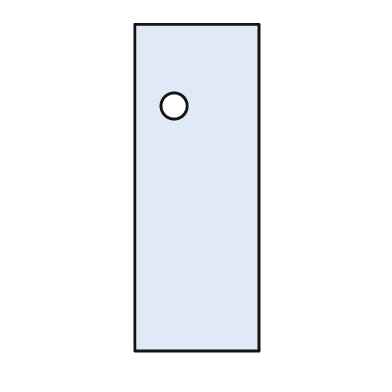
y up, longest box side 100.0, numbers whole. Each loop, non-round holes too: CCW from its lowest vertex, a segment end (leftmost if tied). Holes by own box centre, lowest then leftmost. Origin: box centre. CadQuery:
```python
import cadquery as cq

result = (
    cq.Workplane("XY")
    .moveTo(-19.0, -50.0)
    .lineTo(19.0, -50.0)
    .lineTo(19.0, 50.0)
    .lineTo(-19.0, 50.0)
    .close()
    .moveTo(-7.0, 25.0)
    .circle(4.0)
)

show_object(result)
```